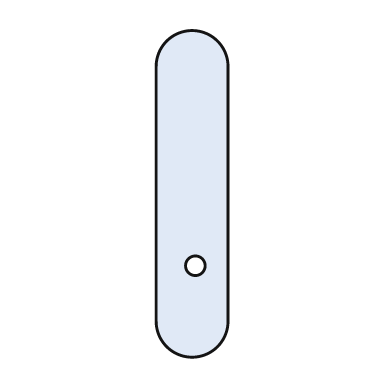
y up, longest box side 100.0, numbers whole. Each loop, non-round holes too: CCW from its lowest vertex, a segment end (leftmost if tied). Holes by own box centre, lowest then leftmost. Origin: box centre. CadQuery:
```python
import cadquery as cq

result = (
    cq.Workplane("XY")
    .moveTo(-11.0, -39.0)
    .threePointArc((0.0, -50.0), (11.0, -39.0))
    .lineTo(11.0, 39.0)
    .threePointArc((0.0, 50.0), (-11.0, 39.0))
    .close()
    .moveTo(1.0, -22.0)
    .circle(3.0)
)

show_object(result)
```